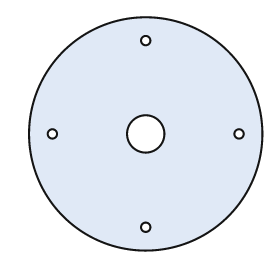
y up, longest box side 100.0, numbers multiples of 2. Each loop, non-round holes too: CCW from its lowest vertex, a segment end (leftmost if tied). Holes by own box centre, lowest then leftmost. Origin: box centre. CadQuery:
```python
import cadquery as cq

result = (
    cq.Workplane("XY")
    .moveTo(0.0, 0.0)
    .circle(50.0)
    .moveTo(0.0, -40.0)
    .circle(2.0)
    .moveTo(-40.0, 0.0)
    .circle(2.0)
    .moveTo(0.0, 0.0)
    .circle(8.0)
    .moveTo(40.0, 0.0)
    .circle(2.0)
    .moveTo(0.0, 40.0)
    .circle(2.0)
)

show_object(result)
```